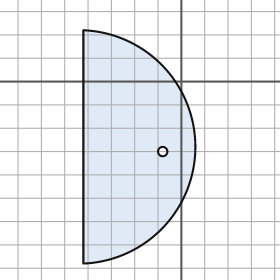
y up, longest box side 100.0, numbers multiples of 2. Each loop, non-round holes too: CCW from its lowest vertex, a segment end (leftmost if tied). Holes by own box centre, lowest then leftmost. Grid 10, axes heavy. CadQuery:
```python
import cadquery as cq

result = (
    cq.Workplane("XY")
    .moveTo(-42.0, -78.0)
    .threePointArc((6.0, -28.0), (-42.0, 22.0))
    .close()
    .moveTo(-8.0, -30.0)
    .circle(2.0)
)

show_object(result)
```